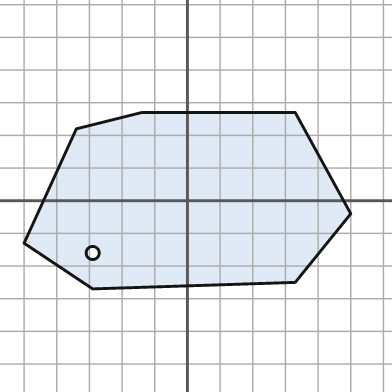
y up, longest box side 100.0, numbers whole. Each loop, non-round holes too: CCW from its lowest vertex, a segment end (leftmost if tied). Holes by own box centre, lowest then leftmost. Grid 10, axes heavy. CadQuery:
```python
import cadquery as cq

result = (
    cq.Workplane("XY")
    .moveTo(-29.0, -27.0)
    .lineTo(33.0, -25.0)
    .lineTo(50.0, -4.0)
    .lineTo(33.0, 27.0)
    .lineTo(-14.0, 27.0)
    .lineTo(-34.0, 22.0)
    .lineTo(-50.0, -13.0)
    .close()
    .moveTo(-29.0, -16.0)
    .circle(2.0)
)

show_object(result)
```